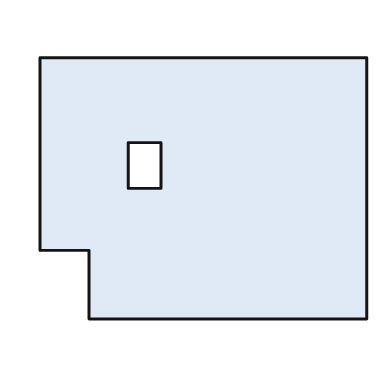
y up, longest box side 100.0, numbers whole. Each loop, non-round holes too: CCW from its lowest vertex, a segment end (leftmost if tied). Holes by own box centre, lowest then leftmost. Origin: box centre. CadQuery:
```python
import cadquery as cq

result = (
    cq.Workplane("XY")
    .moveTo(-35.0, -40.0)
    .lineTo(50.0, -40.0)
    .lineTo(50.0, 40.0)
    .lineTo(-50.0, 40.0)
    .lineTo(-50.0, -19.0)
    .lineTo(-35.0, -19.0)
    .close()
    .moveTo(-23.0, 0.0)
    .lineTo(-13.0, 0.0)
    .lineTo(-13.0, 14.0)
    .lineTo(-23.0, 14.0)
    .close()
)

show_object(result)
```